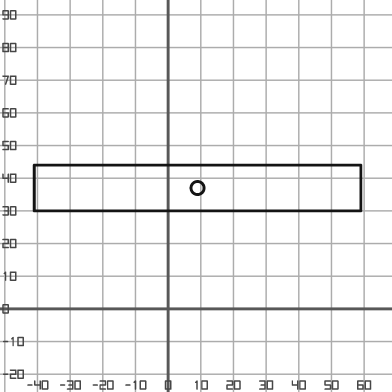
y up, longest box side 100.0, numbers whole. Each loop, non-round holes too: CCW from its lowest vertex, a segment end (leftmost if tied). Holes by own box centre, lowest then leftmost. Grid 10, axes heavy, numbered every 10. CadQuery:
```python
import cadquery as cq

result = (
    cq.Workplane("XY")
    .moveTo(-41.0, 30.0)
    .lineTo(59.0, 30.0)
    .lineTo(59.0, 44.0)
    .lineTo(-41.0, 44.0)
    .close()
    .moveTo(9.0, 37.0)
    .circle(2.0)
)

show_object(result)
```